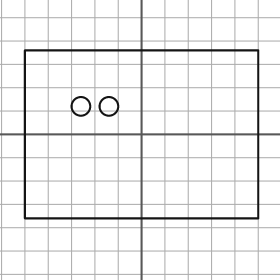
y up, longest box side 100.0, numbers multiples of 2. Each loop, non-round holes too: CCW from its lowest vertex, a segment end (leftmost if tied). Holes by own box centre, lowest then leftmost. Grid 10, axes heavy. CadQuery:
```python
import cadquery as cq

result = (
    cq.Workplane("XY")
    .moveTo(-50.0, -36.0)
    .lineTo(50.0, -36.0)
    .lineTo(50.0, 36.0)
    .lineTo(-50.0, 36.0)
    .close()
    .moveTo(-26.0, 12.0)
    .circle(4.0)
    .moveTo(-14.0, 12.0)
    .circle(4.0)
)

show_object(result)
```